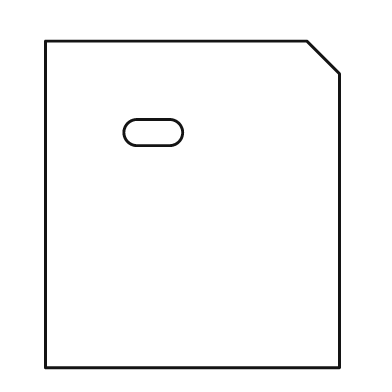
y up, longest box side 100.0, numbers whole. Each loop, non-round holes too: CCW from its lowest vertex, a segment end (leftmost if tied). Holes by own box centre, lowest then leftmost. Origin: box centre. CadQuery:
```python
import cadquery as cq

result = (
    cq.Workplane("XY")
    .moveTo(-45.0, -50.0)
    .lineTo(45.0, -50.0)
    .lineTo(45.0, 40.0)
    .lineTo(35.0, 50.0)
    .lineTo(-45.0, 50.0)
    .close()
    .moveTo(-17.0, 18.0)
    .lineTo(-7.0, 18.0)
    .threePointArc((-3.0, 22.0), (-7.0, 26.0))
    .lineTo(-17.0, 26.0)
    .threePointArc((-21.0, 22.0), (-17.0, 18.0))
    .close()
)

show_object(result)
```